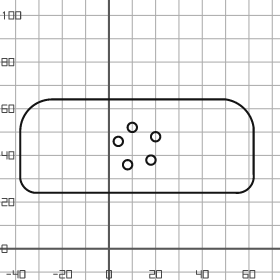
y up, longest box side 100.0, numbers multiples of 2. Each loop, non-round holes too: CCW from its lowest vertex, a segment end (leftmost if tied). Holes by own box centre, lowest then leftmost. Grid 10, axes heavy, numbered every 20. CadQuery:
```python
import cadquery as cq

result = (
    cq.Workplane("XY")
    .moveTo(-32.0, 24.0)
    .lineTo(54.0, 24.0)
    .threePointArc((60.0, 26.0), (62.0, 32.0))
    .lineTo(62.0, 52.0)
    .threePointArc((58.0, 60.0), (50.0, 64.0))
    .lineTo(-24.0, 64.0)
    .threePointArc((-34.0, 60.0), (-38.0, 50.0))
    .lineTo(-38.0, 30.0)
    .threePointArc((-36.0, 26.0), (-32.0, 24.0))
    .close()
    .moveTo(8.0, 36.0)
    .circle(2.0)
    .moveTo(18.0, 38.0)
    .circle(2.0)
    .moveTo(4.0, 46.0)
    .circle(2.0)
    .moveTo(20.0, 48.0)
    .circle(2.0)
    .moveTo(10.0, 52.0)
    .circle(2.0)
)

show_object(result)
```